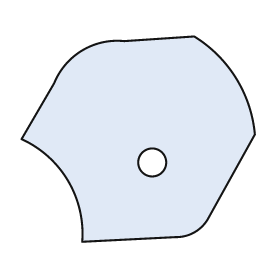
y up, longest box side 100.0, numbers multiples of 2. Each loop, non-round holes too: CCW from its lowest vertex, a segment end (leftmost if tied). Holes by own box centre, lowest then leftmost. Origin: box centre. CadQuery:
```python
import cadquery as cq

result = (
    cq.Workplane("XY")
    .moveTo(-24.0, -44.0)
    .lineTo(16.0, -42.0)
    .threePointArc((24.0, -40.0), (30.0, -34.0))
    .lineTo(50.0, 2.0)
    .threePointArc((42.0, 26.0), (24.0, 44.0))
    .lineTo(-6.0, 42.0)
    .threePointArc((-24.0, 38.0), (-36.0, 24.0))
    .lineTo(-50.0, 0.0)
    .threePointArc((-30.0, -18.0), (-24.0, -44.0))
    .close()
    .moveTo(6.0, -10.0)
    .circle(6.0)
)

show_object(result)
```